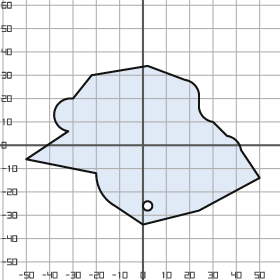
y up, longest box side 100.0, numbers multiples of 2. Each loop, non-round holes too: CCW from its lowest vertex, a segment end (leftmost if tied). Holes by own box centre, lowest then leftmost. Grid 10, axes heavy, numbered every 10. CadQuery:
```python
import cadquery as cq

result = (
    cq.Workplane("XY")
    .moveTo(0.0, -34.0)
    .lineTo(24.0, -28.0)
    .lineTo(50.0, -14.0)
    .lineTo(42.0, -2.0)
    .threePointArc((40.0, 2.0), (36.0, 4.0))
    .lineTo(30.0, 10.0)
    .threePointArc((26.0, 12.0), (24.0, 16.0))
    .lineTo(24.0, 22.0)
    .threePointArc((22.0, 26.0), (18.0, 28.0))
    .lineTo(2.0, 34.0)
    .lineTo(-22.0, 30.0)
    .lineTo(-30.0, 20.0)
    .threePointArc((-38.0, 14.0), (-32.0, 6.0))
    .lineTo(-50.0, -6.0)
    .lineTo(-20.0, -12.0)
    .threePointArc((-18.0, -20.0), (-12.0, -26.0))
    .close()
    .moveTo(2.0, -26.0)
    .circle(2.0)
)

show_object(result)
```